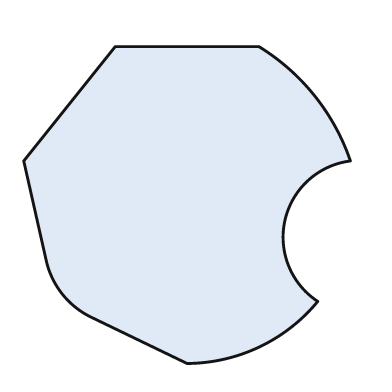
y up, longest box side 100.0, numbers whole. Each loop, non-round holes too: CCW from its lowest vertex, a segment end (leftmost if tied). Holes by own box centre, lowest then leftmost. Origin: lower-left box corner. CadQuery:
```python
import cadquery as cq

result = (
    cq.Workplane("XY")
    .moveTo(50.0, 0.0)
    .threePointArc((72.0, 5.0), (90.0, 19.0))
    .threePointArc((80.0, 44.0), (100.0, 62.0))
    .threePointArc((89.0, 82.0), (72.0, 97.0))
    .lineTo(28.0, 97.0)
    .lineTo(0.0, 62.0)
    .lineTo(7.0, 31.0)
    .threePointArc((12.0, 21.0), (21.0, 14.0))
    .close()
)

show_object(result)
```